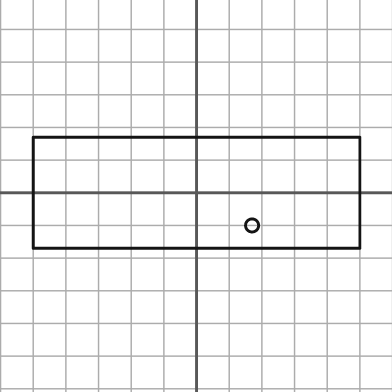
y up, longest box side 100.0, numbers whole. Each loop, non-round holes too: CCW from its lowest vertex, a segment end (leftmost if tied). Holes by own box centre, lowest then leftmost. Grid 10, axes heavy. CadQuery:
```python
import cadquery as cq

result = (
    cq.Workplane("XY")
    .moveTo(-50.0, -17.0)
    .lineTo(50.0, -17.0)
    .lineTo(50.0, 17.0)
    .lineTo(-50.0, 17.0)
    .close()
    .moveTo(17.0, -10.0)
    .circle(2.0)
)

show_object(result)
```